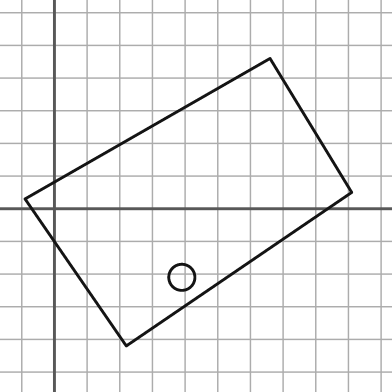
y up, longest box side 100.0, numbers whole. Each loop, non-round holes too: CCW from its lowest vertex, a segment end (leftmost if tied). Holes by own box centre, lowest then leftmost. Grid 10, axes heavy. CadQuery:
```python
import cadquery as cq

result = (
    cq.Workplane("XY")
    .moveTo(22.0, -42.0)
    .lineTo(91.0, 5.0)
    .lineTo(66.0, 46.0)
    .lineTo(-9.0, 3.0)
    .close()
    .moveTo(39.0, -21.0)
    .circle(4.0)
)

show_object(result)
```